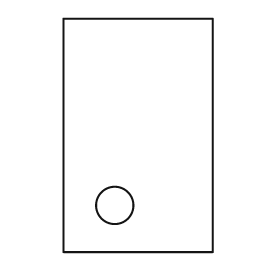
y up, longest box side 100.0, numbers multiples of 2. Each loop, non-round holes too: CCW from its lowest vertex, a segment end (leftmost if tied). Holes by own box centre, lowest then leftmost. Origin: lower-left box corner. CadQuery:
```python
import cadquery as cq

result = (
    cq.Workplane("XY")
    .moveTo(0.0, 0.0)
    .lineTo(64.0, 0.0)
    .lineTo(64.0, 100.0)
    .lineTo(0.0, 100.0)
    .close()
    .moveTo(22.0, 20.0)
    .circle(8.0)
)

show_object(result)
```